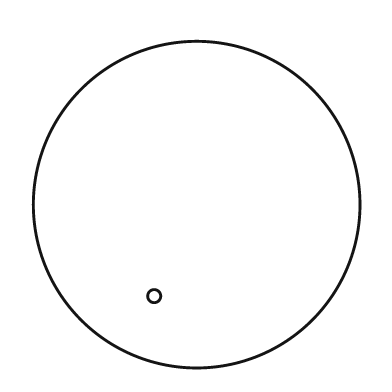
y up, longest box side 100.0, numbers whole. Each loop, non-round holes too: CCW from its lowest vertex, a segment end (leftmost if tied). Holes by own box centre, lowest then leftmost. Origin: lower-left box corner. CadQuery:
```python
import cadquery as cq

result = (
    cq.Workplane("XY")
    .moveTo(50.0, 50.0)
    .circle(50.0)
    .moveTo(37.0, 22.0)
    .circle(2.0)
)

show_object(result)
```